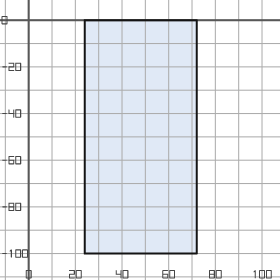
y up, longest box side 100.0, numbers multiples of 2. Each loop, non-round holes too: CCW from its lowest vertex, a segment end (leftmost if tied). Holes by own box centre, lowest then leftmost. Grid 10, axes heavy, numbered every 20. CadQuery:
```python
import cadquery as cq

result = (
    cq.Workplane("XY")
    .moveTo(24.0, -100.0)
    .lineTo(72.0, -100.0)
    .lineTo(72.0, 0.0)
    .lineTo(24.0, 0.0)
    .close()
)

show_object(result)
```